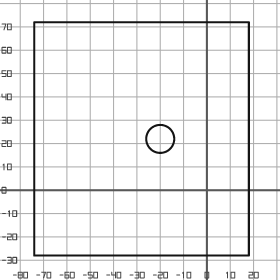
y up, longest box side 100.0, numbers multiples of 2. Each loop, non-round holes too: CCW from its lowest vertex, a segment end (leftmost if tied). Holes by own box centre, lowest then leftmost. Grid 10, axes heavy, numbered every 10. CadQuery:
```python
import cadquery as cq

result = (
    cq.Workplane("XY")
    .moveTo(-74.0, -28.0)
    .lineTo(18.0, -28.0)
    .lineTo(18.0, 72.0)
    .lineTo(-74.0, 72.0)
    .close()
    .moveTo(-20.0, 22.0)
    .circle(6.0)
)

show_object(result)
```